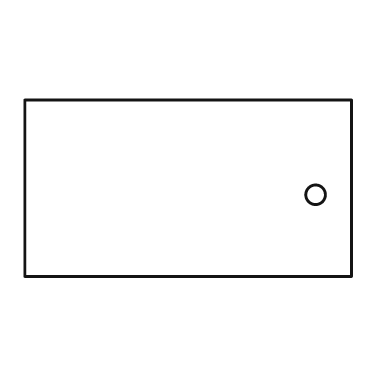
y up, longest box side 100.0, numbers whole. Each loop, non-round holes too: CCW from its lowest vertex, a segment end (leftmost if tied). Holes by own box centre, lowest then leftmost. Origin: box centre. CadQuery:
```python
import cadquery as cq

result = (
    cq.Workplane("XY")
    .moveTo(-50.0, -27.0)
    .lineTo(50.0, -27.0)
    .lineTo(50.0, 27.0)
    .lineTo(-50.0, 27.0)
    .close()
    .moveTo(39.0, -2.0)
    .circle(3.0)
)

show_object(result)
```